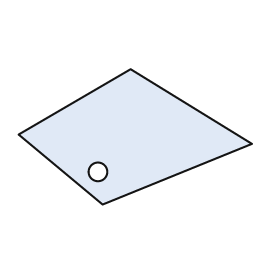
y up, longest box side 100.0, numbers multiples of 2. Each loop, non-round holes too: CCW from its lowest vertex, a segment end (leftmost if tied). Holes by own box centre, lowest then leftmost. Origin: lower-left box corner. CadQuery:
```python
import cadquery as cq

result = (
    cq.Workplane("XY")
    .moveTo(36.0, 0.0)
    .lineTo(100.0, 26.0)
    .lineTo(48.0, 58.0)
    .lineTo(0.0, 30.0)
    .close()
    .moveTo(34.0, 14.0)
    .circle(4.0)
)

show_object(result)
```